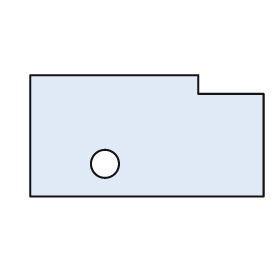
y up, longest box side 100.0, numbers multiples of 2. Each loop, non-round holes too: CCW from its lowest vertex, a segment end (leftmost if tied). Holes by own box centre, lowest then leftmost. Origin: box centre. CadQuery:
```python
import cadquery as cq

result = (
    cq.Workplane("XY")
    .moveTo(-50.0, -26.0)
    .lineTo(50.0, -26.0)
    .lineTo(50.0, 18.0)
    .lineTo(22.0, 18.0)
    .lineTo(22.0, 26.0)
    .lineTo(-50.0, 26.0)
    .close()
    .moveTo(-18.0, -12.0)
    .circle(6.0)
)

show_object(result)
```